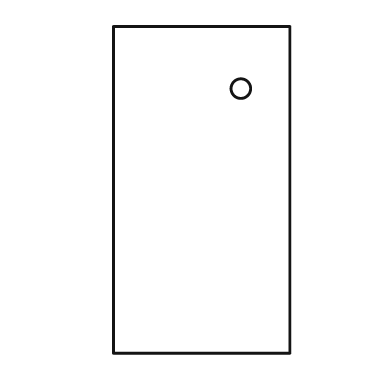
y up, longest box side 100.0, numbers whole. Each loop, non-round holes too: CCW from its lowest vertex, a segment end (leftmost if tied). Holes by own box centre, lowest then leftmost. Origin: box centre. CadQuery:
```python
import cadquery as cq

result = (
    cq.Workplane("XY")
    .moveTo(-27.0, -50.0)
    .lineTo(27.0, -50.0)
    .lineTo(27.0, 50.0)
    .lineTo(-27.0, 50.0)
    .close()
    .moveTo(12.0, 31.0)
    .circle(3.0)
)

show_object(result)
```